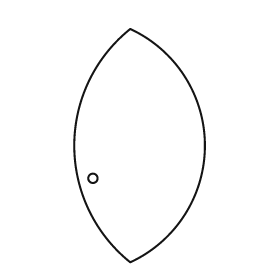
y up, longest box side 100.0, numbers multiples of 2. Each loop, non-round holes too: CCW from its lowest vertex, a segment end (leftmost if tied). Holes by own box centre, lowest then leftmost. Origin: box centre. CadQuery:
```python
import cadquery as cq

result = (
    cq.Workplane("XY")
    .moveTo(-4.0, -50.0)
    .threePointArc((28.0, 0.0), (-4.0, 50.0))
    .threePointArc((-28.0, 0.0), (-4.0, -50.0))
    .close()
    .moveTo(-20.0, -14.0)
    .circle(2.0)
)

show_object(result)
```